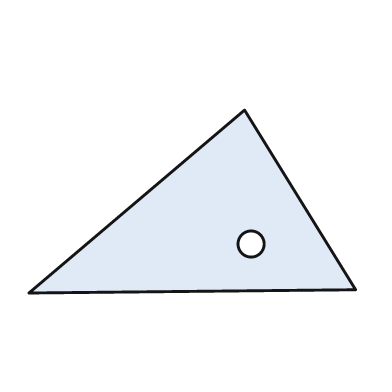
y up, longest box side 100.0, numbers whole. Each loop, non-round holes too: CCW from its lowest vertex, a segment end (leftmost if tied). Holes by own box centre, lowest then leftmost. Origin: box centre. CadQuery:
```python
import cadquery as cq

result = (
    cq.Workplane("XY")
    .moveTo(-50.0, -28.0)
    .lineTo(50.0, -27.0)
    .lineTo(16.0, 28.0)
    .close()
    .moveTo(18.0, -13.0)
    .circle(4.0)
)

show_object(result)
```